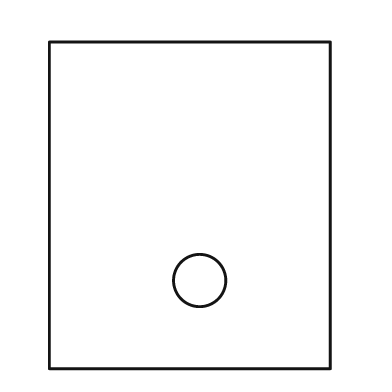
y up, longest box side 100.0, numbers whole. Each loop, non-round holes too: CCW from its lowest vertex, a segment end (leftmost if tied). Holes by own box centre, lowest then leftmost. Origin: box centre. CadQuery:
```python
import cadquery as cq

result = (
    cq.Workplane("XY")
    .moveTo(-43.0, -50.0)
    .lineTo(43.0, -50.0)
    .lineTo(43.0, 50.0)
    .lineTo(-43.0, 50.0)
    .close()
    .moveTo(3.0, -23.0)
    .circle(8.0)
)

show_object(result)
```